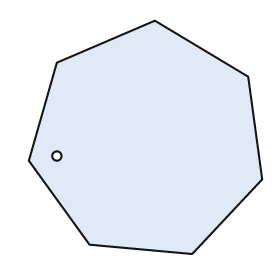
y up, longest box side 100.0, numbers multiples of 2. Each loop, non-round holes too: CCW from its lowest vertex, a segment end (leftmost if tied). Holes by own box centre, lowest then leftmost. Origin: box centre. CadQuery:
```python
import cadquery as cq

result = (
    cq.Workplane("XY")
    .moveTo(20.0, -50.0)
    .lineTo(50.0, -18.0)
    .lineTo(44.0, 26.0)
    .lineTo(4.0, 50.0)
    .lineTo(-38.0, 32.0)
    .lineTo(-50.0, -10.0)
    .lineTo(-24.0, -46.0)
    .close()
    .moveTo(-38.0, -8.0)
    .circle(2.0)
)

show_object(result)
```